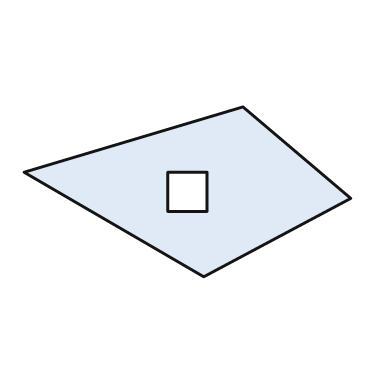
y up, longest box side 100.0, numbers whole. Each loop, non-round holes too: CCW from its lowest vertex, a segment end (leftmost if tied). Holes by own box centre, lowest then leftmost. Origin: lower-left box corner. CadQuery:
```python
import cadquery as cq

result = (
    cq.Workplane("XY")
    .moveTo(55.0, 0.0)
    .lineTo(100.0, 24.0)
    .lineTo(67.0, 52.0)
    .lineTo(0.0, 32.0)
    .close()
    .moveTo(44.0, 20.0)
    .lineTo(56.0, 20.0)
    .lineTo(56.0, 32.0)
    .lineTo(44.0, 32.0)
    .close()
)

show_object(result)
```